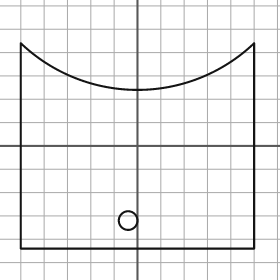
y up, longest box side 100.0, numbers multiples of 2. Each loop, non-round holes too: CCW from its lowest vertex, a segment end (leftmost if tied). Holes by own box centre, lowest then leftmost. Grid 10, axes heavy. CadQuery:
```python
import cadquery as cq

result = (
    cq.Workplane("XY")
    .moveTo(-50.0, -44.0)
    .lineTo(50.0, -44.0)
    .lineTo(50.0, 44.0)
    .threePointArc((0.0, 24.0), (-50.0, 44.0))
    .close()
    .moveTo(-4.0, -32.0)
    .circle(4.0)
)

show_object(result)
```